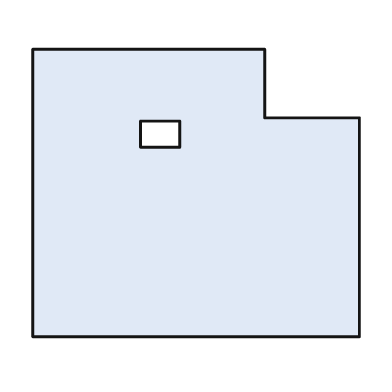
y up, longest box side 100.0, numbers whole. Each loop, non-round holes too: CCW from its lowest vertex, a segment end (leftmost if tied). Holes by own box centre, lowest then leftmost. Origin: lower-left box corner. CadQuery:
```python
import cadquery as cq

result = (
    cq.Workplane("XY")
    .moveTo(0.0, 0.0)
    .lineTo(100.0, 0.0)
    .lineTo(100.0, 67.0)
    .lineTo(71.0, 67.0)
    .lineTo(71.0, 88.0)
    .lineTo(0.0, 88.0)
    .close()
    .moveTo(33.0, 58.0)
    .lineTo(45.0, 58.0)
    .lineTo(45.0, 66.0)
    .lineTo(33.0, 66.0)
    .close()
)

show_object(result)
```